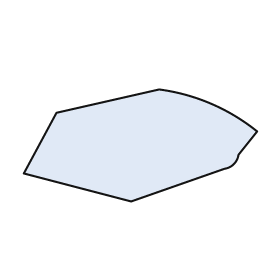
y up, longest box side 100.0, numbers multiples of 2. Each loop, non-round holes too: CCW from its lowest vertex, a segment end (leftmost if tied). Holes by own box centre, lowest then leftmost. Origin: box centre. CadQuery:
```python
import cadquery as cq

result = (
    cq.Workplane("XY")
    .moveTo(-4.0, -24.0)
    .lineTo(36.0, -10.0)
    .threePointArc((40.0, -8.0), (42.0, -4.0))
    .lineTo(50.0, 6.0)
    .threePointArc((30.0, 18.0), (8.0, 24.0))
    .lineTo(-36.0, 14.0)
    .lineTo(-50.0, -12.0)
    .close()
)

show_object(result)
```